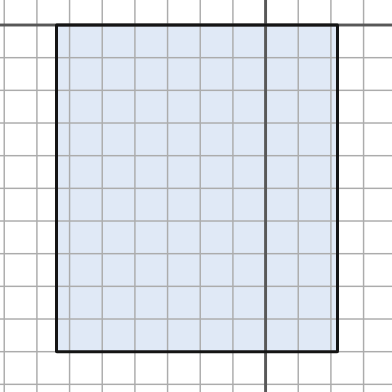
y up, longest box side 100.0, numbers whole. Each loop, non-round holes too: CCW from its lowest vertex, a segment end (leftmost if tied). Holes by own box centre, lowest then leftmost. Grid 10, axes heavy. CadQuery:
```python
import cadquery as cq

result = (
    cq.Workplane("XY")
    .moveTo(-64.0, -100.0)
    .lineTo(22.0, -100.0)
    .lineTo(22.0, 0.0)
    .lineTo(-64.0, 0.0)
    .close()
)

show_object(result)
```